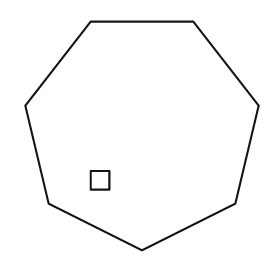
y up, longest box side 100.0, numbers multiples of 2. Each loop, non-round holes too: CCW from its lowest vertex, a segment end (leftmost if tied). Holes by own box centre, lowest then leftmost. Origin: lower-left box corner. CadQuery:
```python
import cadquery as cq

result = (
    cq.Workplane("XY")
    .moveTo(50.0, 0.0)
    .lineTo(90.0, 20.0)
    .lineTo(100.0, 62.0)
    .lineTo(72.0, 98.0)
    .lineTo(28.0, 98.0)
    .lineTo(0.0, 62.0)
    .lineTo(10.0, 20.0)
    .close()
    .moveTo(28.0, 26.0)
    .lineTo(36.0, 26.0)
    .lineTo(36.0, 34.0)
    .lineTo(28.0, 34.0)
    .close()
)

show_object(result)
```